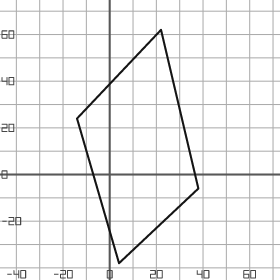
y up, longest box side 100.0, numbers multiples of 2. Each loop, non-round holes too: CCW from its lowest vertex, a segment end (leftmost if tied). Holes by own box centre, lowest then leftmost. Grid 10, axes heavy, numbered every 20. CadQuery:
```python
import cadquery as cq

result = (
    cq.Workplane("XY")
    .moveTo(4.0, -38.0)
    .lineTo(38.0, -6.0)
    .lineTo(22.0, 62.0)
    .lineTo(-14.0, 24.0)
    .close()
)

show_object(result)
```